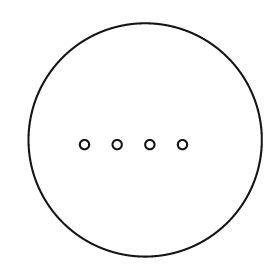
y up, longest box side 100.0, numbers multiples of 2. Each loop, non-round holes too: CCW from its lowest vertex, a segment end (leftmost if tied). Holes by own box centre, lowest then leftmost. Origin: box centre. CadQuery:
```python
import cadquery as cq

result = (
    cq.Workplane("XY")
    .moveTo(0.0, 0.0)
    .circle(50.0)
    .moveTo(-26.0, -2.0)
    .circle(2.0)
    .moveTo(-12.0, -2.0)
    .circle(2.0)
    .moveTo(2.0, -2.0)
    .circle(2.0)
    .moveTo(16.0, -2.0)
    .circle(2.0)
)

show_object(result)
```